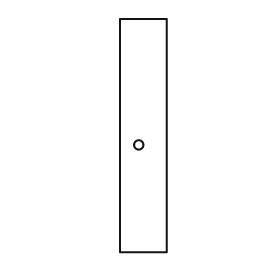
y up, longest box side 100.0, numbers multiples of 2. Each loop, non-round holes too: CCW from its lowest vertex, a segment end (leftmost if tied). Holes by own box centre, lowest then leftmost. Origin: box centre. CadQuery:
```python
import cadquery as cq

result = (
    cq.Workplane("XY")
    .moveTo(-10.0, -50.0)
    .lineTo(10.0, -50.0)
    .lineTo(10.0, 50.0)
    .lineTo(-10.0, 50.0)
    .close()
    .moveTo(-2.0, -4.0)
    .circle(2.0)
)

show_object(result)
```